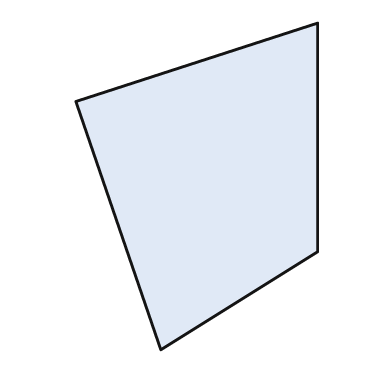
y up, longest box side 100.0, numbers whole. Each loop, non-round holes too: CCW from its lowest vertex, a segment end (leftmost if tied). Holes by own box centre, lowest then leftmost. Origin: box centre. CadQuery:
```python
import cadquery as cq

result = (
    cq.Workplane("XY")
    .moveTo(-11.0, -50.0)
    .lineTo(37.0, -20.0)
    .lineTo(37.0, 50.0)
    .lineTo(-37.0, 26.0)
    .close()
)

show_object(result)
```